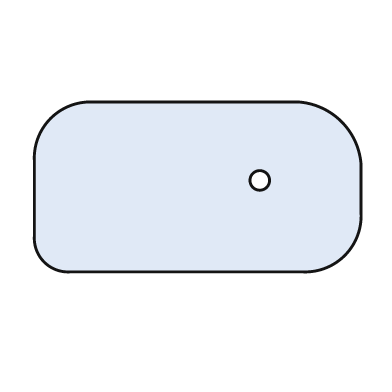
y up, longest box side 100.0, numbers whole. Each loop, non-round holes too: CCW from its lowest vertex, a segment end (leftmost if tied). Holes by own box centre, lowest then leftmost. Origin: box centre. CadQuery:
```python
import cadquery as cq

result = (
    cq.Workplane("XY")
    .moveTo(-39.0, -26.0)
    .lineTo(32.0, -26.0)
    .threePointArc((45.0, -21.0), (50.0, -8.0))
    .lineTo(50.0, 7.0)
    .threePointArc((44.0, 20.0), (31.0, 26.0))
    .lineTo(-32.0, 26.0)
    .threePointArc((-45.0, 21.0), (-50.0, 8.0))
    .lineTo(-50.0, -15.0)
    .threePointArc((-47.0, -23.0), (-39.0, -26.0))
    .close()
    .moveTo(19.0, 2.0)
    .circle(3.0)
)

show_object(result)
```